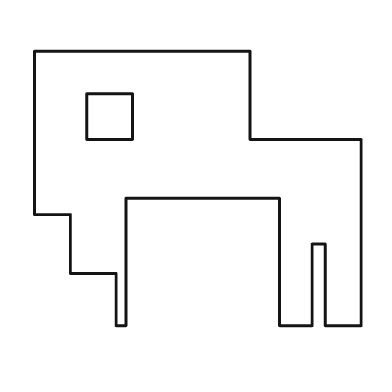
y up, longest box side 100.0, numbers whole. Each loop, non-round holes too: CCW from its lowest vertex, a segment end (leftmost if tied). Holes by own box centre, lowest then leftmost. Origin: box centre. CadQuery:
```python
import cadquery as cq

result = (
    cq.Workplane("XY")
    .moveTo(-25.0, -42.0)
    .lineTo(-22.0, -42.0)
    .lineTo(-22.0, -3.0)
    .lineTo(25.0, -3.0)
    .lineTo(25.0, -42.0)
    .lineTo(35.0, -42.0)
    .lineTo(35.0, -17.0)
    .lineTo(39.0, -17.0)
    .lineTo(39.0, -42.0)
    .lineTo(50.0, -42.0)
    .lineTo(50.0, 15.0)
    .lineTo(16.0, 15.0)
    .lineTo(16.0, 42.0)
    .lineTo(-50.0, 42.0)
    .lineTo(-50.0, -8.0)
    .lineTo(-39.0, -8.0)
    .lineTo(-39.0, -26.0)
    .lineTo(-25.0, -26.0)
    .close()
    .moveTo(-34.0, 15.0)
    .lineTo(-20.0, 15.0)
    .lineTo(-20.0, 29.0)
    .lineTo(-34.0, 29.0)
    .close()
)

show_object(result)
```